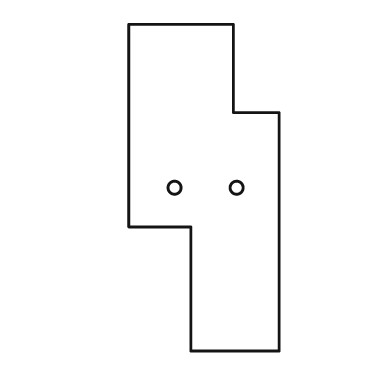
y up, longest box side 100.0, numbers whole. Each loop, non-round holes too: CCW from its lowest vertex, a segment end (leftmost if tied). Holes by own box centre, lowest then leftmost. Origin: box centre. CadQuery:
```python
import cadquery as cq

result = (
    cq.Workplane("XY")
    .moveTo(-4.0, -50.0)
    .lineTo(23.0, -50.0)
    .lineTo(23.0, 23.0)
    .lineTo(9.0, 23.0)
    .lineTo(9.0, 50.0)
    .lineTo(-23.0, 50.0)
    .lineTo(-23.0, -12.0)
    .lineTo(-4.0, -12.0)
    .close()
    .moveTo(-9.0, 0.0)
    .circle(2.0)
    .moveTo(10.0, 0.0)
    .circle(2.0)
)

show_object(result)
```